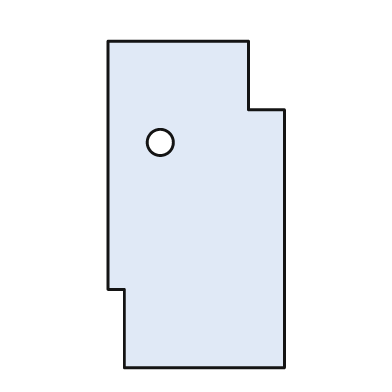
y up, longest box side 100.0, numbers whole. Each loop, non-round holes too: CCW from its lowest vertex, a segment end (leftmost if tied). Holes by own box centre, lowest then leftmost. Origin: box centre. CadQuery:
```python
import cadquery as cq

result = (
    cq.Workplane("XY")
    .moveTo(-22.0, -50.0)
    .lineTo(27.0, -50.0)
    .lineTo(27.0, 29.0)
    .lineTo(16.0, 29.0)
    .lineTo(16.0, 50.0)
    .lineTo(-27.0, 50.0)
    .lineTo(-27.0, -26.0)
    .lineTo(-22.0, -26.0)
    .close()
    .moveTo(-11.0, 19.0)
    .circle(4.0)
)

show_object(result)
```